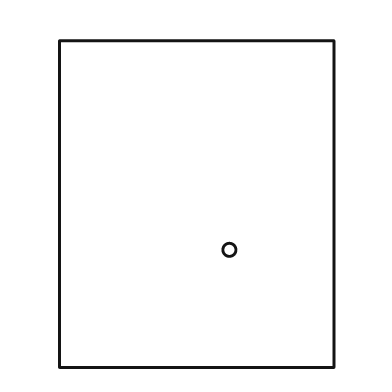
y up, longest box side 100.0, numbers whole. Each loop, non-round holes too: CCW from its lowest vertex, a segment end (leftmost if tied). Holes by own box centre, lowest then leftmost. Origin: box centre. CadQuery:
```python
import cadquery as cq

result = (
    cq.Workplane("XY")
    .moveTo(-42.0, -50.0)
    .lineTo(42.0, -50.0)
    .lineTo(42.0, 50.0)
    .lineTo(-42.0, 50.0)
    .close()
    .moveTo(10.0, -14.0)
    .circle(2.0)
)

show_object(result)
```